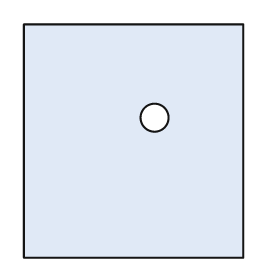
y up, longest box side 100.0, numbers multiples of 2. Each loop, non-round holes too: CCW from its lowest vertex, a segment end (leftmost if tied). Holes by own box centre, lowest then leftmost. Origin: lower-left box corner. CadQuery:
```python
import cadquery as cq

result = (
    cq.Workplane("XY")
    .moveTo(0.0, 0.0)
    .lineTo(94.0, 0.0)
    .lineTo(94.0, 100.0)
    .lineTo(0.0, 100.0)
    .close()
    .moveTo(56.0, 60.0)
    .circle(6.0)
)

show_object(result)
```